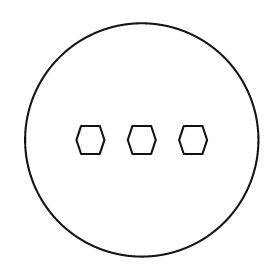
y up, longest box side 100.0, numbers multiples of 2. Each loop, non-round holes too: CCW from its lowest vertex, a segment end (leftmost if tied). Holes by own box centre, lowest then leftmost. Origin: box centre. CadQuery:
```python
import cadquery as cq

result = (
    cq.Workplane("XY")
    .moveTo(0.0, 0.0)
    .circle(50.0)
    .moveTo(-26.0, -6.0)
    .lineTo(-18.0, -6.0)
    .lineTo(-16.0, 0.0)
    .lineTo(-18.0, 6.0)
    .lineTo(-26.0, 6.0)
    .lineTo(-28.0, 0.0)
    .close()
    .moveTo(-4.0, -6.0)
    .lineTo(4.0, -6.0)
    .lineTo(6.0, 0.0)
    .lineTo(4.0, 6.0)
    .lineTo(-4.0, 6.0)
    .lineTo(-6.0, 0.0)
    .close()
    .moveTo(18.0, -6.0)
    .lineTo(26.0, -6.0)
    .lineTo(28.0, 0.0)
    .lineTo(26.0, 6.0)
    .lineTo(18.0, 6.0)
    .lineTo(16.0, 0.0)
    .close()
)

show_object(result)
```